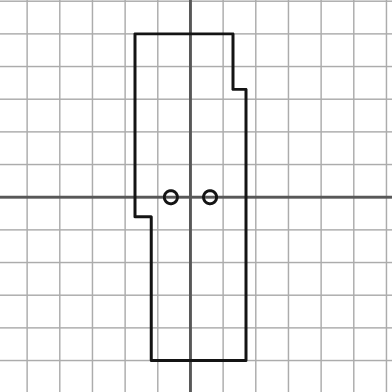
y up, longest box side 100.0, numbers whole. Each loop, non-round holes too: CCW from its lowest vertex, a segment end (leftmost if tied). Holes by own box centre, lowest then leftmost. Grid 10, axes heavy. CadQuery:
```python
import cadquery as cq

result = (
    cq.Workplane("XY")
    .moveTo(-12.0, -50.0)
    .lineTo(17.0, -50.0)
    .lineTo(17.0, 33.0)
    .lineTo(13.0, 33.0)
    .lineTo(13.0, 50.0)
    .lineTo(-17.0, 50.0)
    .lineTo(-17.0, -6.0)
    .lineTo(-12.0, -6.0)
    .close()
    .moveTo(-6.0, 0.0)
    .circle(2.0)
    .moveTo(6.0, 0.0)
    .circle(2.0)
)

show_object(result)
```